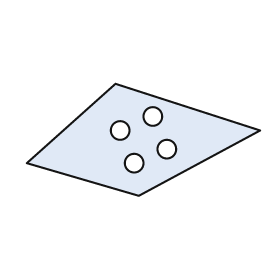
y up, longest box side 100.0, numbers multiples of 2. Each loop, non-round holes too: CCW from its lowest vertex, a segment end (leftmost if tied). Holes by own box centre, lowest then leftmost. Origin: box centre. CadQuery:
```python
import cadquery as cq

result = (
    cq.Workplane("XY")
    .moveTo(-2.0, -24.0)
    .lineTo(50.0, 4.0)
    .lineTo(-12.0, 24.0)
    .lineTo(-50.0, -10.0)
    .close()
    .moveTo(-4.0, -10.0)
    .circle(4.0)
    .moveTo(10.0, -4.0)
    .circle(4.0)
    .moveTo(-10.0, 4.0)
    .circle(4.0)
    .moveTo(4.0, 10.0)
    .circle(4.0)
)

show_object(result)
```